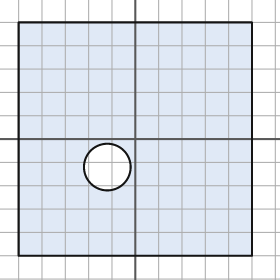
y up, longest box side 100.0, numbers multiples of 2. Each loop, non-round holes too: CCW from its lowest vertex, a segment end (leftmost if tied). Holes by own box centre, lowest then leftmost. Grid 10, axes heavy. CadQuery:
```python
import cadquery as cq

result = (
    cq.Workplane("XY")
    .moveTo(-50.0, -50.0)
    .lineTo(50.0, -50.0)
    .lineTo(50.0, 50.0)
    .lineTo(-50.0, 50.0)
    .close()
    .moveTo(-12.0, -12.0)
    .circle(10.0)
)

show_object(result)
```